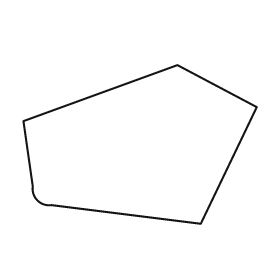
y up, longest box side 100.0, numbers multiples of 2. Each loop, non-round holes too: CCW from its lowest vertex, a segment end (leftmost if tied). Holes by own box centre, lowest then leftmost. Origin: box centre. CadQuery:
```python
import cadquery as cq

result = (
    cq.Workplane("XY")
    .moveTo(26.0, -34.0)
    .lineTo(50.0, 16.0)
    .lineTo(16.0, 34.0)
    .lineTo(-50.0, 10.0)
    .lineTo(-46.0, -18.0)
    .threePointArc((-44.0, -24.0), (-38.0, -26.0))
    .close()
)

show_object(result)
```